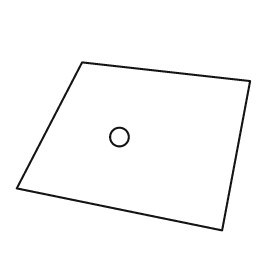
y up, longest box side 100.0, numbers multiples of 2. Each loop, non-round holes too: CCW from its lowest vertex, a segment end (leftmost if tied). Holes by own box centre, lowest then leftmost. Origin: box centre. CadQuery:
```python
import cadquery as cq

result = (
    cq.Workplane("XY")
    .moveTo(38.0, -36.0)
    .lineTo(50.0, 28.0)
    .lineTo(-22.0, 36.0)
    .lineTo(-50.0, -18.0)
    .close()
    .moveTo(-6.0, 4.0)
    .circle(4.0)
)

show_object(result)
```